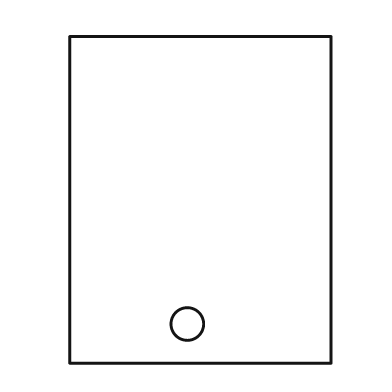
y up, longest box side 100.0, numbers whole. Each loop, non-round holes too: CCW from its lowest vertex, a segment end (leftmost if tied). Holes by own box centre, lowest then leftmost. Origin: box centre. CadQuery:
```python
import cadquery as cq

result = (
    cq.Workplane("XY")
    .moveTo(-40.0, -50.0)
    .lineTo(40.0, -50.0)
    .lineTo(40.0, 50.0)
    .lineTo(-40.0, 50.0)
    .close()
    .moveTo(-4.0, -38.0)
    .circle(5.0)
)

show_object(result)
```